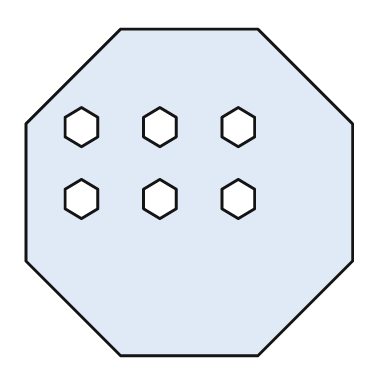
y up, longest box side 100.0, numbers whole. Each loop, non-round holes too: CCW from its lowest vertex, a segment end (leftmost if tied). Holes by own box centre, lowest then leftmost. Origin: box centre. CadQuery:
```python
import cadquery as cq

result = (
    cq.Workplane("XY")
    .moveTo(-21.0, -50.0)
    .lineTo(21.0, -50.0)
    .lineTo(50.0, -21.0)
    .lineTo(50.0, 21.0)
    .lineTo(21.0, 50.0)
    .lineTo(-21.0, 50.0)
    .lineTo(-50.0, 21.0)
    .lineTo(-50.0, -21.0)
    .close()
    .moveTo(-33.0, -8.0)
    .lineTo(-28.0, -5.0)
    .lineTo(-28.0, 1.0)
    .lineTo(-33.0, 4.0)
    .lineTo(-38.0, 1.0)
    .lineTo(-38.0, -5.0)
    .close()
    .moveTo(-9.0, -8.0)
    .lineTo(-4.0, -5.0)
    .lineTo(-4.0, 1.0)
    .lineTo(-9.0, 4.0)
    .lineTo(-14.0, 1.0)
    .lineTo(-14.0, -5.0)
    .close()
    .moveTo(15.0, -8.0)
    .lineTo(20.0, -5.0)
    .lineTo(20.0, 1.0)
    .lineTo(15.0, 4.0)
    .lineTo(10.0, 1.0)
    .lineTo(10.0, -5.0)
    .close()
    .moveTo(-33.0, 14.0)
    .lineTo(-28.0, 17.0)
    .lineTo(-28.0, 23.0)
    .lineTo(-33.0, 26.0)
    .lineTo(-38.0, 23.0)
    .lineTo(-38.0, 17.0)
    .close()
    .moveTo(-9.0, 14.0)
    .lineTo(-4.0, 17.0)
    .lineTo(-4.0, 23.0)
    .lineTo(-9.0, 26.0)
    .lineTo(-14.0, 23.0)
    .lineTo(-14.0, 17.0)
    .close()
    .moveTo(15.0, 14.0)
    .lineTo(20.0, 17.0)
    .lineTo(20.0, 23.0)
    .lineTo(15.0, 26.0)
    .lineTo(10.0, 23.0)
    .lineTo(10.0, 17.0)
    .close()
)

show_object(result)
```